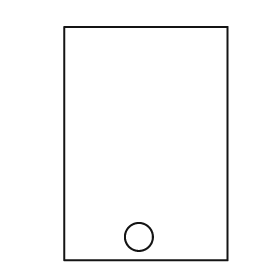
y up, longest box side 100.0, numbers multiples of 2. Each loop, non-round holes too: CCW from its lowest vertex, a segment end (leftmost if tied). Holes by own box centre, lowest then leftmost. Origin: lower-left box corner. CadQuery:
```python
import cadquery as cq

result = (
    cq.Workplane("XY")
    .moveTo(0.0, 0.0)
    .lineTo(70.0, 0.0)
    .lineTo(70.0, 100.0)
    .lineTo(0.0, 100.0)
    .close()
    .moveTo(32.0, 10.0)
    .circle(6.0)
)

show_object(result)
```